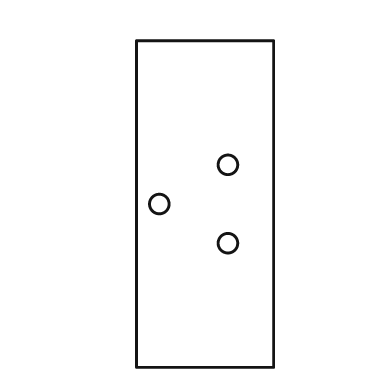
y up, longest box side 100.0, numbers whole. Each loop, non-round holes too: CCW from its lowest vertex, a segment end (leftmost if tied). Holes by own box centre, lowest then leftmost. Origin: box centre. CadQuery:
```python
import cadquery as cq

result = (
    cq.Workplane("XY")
    .moveTo(-21.0, -50.0)
    .lineTo(21.0, -50.0)
    .lineTo(21.0, 50.0)
    .lineTo(-21.0, 50.0)
    .close()
    .moveTo(7.0, -12.0)
    .circle(3.0)
    .moveTo(-14.0, 0.0)
    .circle(3.0)
    .moveTo(7.0, 12.0)
    .circle(3.0)
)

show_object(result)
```